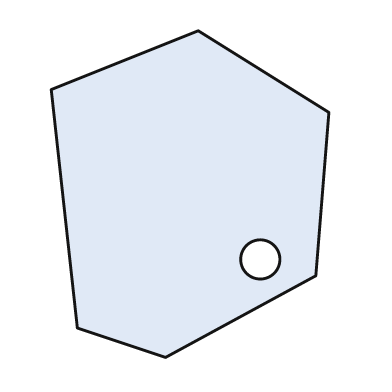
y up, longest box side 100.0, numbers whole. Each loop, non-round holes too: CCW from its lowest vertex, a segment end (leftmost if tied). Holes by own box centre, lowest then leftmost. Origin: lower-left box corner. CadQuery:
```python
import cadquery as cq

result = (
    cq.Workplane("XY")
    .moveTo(35.0, 0.0)
    .lineTo(81.0, 25.0)
    .lineTo(85.0, 75.0)
    .lineTo(45.0, 100.0)
    .lineTo(0.0, 82.0)
    .lineTo(8.0, 9.0)
    .close()
    .moveTo(64.0, 30.0)
    .circle(6.0)
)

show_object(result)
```